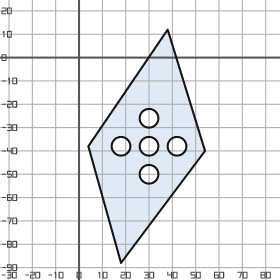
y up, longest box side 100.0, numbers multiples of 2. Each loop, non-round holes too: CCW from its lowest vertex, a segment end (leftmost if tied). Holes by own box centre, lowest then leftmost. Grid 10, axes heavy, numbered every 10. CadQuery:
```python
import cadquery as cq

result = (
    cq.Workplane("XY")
    .moveTo(18.0, -88.0)
    .lineTo(54.0, -40.0)
    .lineTo(38.0, 12.0)
    .lineTo(4.0, -38.0)
    .close()
    .moveTo(30.0, -50.0)
    .circle(4.0)
    .moveTo(18.0, -38.0)
    .circle(4.0)
    .moveTo(30.0, -38.0)
    .circle(4.0)
    .moveTo(42.0, -38.0)
    .circle(4.0)
    .moveTo(30.0, -26.0)
    .circle(4.0)
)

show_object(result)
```